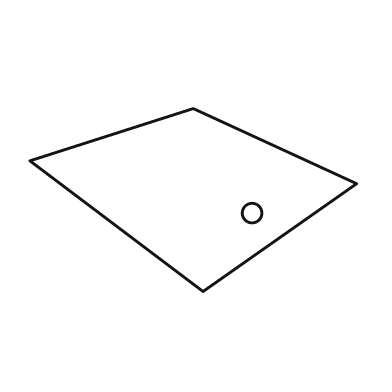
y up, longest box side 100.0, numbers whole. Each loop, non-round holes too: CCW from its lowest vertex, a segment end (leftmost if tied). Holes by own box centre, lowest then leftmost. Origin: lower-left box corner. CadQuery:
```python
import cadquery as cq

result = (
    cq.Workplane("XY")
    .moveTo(53.0, 0.0)
    .lineTo(100.0, 33.0)
    .lineTo(50.0, 56.0)
    .lineTo(0.0, 40.0)
    .close()
    .moveTo(68.0, 24.0)
    .circle(3.0)
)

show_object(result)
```